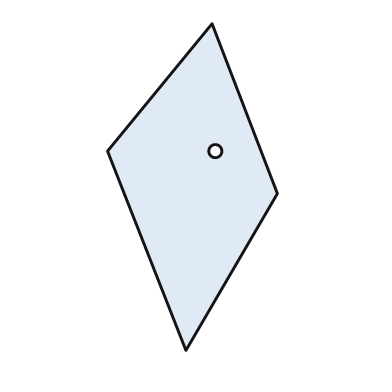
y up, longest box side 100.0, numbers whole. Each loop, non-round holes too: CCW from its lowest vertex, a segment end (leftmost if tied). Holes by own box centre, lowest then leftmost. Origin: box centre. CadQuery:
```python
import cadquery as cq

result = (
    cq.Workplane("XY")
    .moveTo(-2.0, -50.0)
    .lineTo(26.0, -2.0)
    .lineTo(6.0, 50.0)
    .lineTo(-26.0, 11.0)
    .close()
    .moveTo(7.0, 11.0)
    .circle(2.0)
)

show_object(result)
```